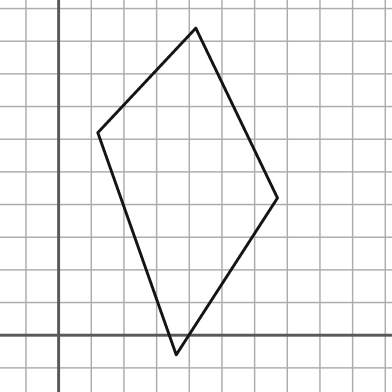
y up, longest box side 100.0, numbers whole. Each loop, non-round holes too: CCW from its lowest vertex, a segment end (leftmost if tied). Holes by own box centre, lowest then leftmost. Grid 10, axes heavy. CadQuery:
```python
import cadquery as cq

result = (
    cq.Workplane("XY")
    .moveTo(36.0, -6.0)
    .lineTo(67.0, 42.0)
    .lineTo(42.0, 94.0)
    .lineTo(12.0, 62.0)
    .close()
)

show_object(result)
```